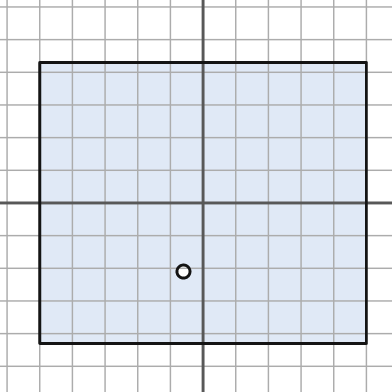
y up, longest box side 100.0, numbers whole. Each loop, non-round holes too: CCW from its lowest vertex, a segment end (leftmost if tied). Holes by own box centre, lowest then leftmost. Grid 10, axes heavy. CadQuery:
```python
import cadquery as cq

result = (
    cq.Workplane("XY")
    .moveTo(-50.0, -43.0)
    .lineTo(50.0, -43.0)
    .lineTo(50.0, 43.0)
    .lineTo(-50.0, 43.0)
    .close()
    .moveTo(-6.0, -21.0)
    .circle(2.0)
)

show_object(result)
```